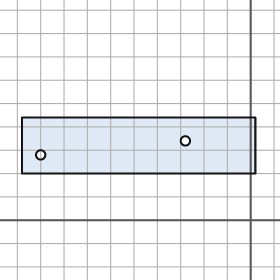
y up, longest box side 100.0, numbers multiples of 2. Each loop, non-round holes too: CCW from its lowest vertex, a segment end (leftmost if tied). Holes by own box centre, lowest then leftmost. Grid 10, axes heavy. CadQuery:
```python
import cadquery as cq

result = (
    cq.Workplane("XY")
    .moveTo(-98.0, 20.0)
    .lineTo(2.0, 20.0)
    .lineTo(2.0, 44.0)
    .lineTo(-98.0, 44.0)
    .close()
    .moveTo(-90.0, 28.0)
    .circle(2.0)
    .moveTo(-28.0, 34.0)
    .circle(2.0)
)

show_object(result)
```